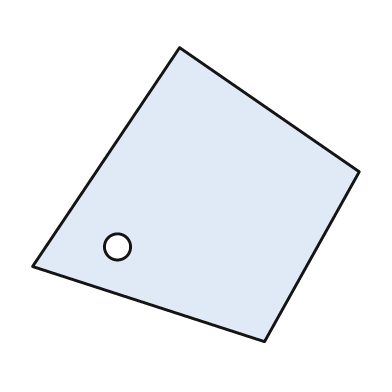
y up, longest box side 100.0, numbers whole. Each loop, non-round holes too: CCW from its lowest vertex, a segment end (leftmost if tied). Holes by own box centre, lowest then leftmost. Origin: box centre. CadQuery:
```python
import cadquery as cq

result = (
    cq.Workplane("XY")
    .moveTo(21.0, -45.0)
    .lineTo(50.0, 7.0)
    .lineTo(-5.0, 45.0)
    .lineTo(-50.0, -22.0)
    .close()
    .moveTo(-24.0, -16.0)
    .circle(4.0)
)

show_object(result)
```